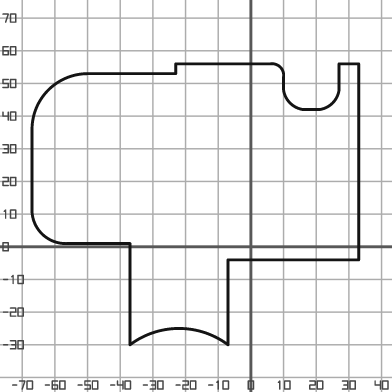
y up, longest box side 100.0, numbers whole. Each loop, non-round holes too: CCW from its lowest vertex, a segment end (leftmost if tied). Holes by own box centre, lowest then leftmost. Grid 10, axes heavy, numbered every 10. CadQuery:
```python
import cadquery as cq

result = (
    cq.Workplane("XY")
    .moveTo(-37.0, -30.0)
    .threePointArc((-22.0, -25.0), (-7.0, -30.0))
    .lineTo(-7.0, -4.0)
    .lineTo(33.0, -4.0)
    .lineTo(33.0, 56.0)
    .lineTo(27.0, 56.0)
    .lineTo(27.0, 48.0)
    .threePointArc((25.0, 44.0), (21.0, 42.0))
    .lineTo(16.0, 42.0)
    .threePointArc((12.0, 44.0), (10.0, 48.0))
    .lineTo(10.0, 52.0)
    .threePointArc((9.0, 55.0), (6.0, 56.0))
    .lineTo(-23.0, 56.0)
    .lineTo(-23.0, 53.0)
    .lineTo(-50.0, 53.0)
    .threePointArc((-62.0, 48.0), (-67.0, 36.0))
    .lineTo(-67.0, 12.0)
    .threePointArc((-64.0, 4.0), (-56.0, 1.0))
    .lineTo(-37.0, 1.0)
    .close()
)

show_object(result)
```